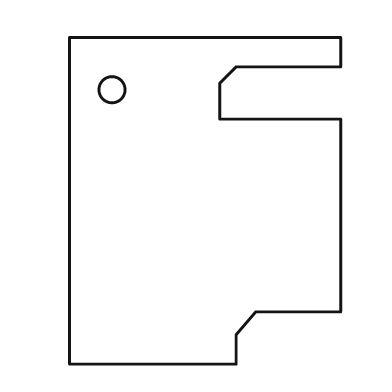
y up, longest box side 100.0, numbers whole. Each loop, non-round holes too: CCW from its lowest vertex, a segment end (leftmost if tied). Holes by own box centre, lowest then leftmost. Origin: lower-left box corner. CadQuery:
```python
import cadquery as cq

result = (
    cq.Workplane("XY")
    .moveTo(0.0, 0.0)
    .lineTo(51.0, 0.0)
    .lineTo(51.0, 9.0)
    .lineTo(57.0, 16.0)
    .lineTo(83.0, 16.0)
    .lineTo(83.0, 75.0)
    .lineTo(46.0, 75.0)
    .lineTo(46.0, 86.0)
    .lineTo(51.0, 91.0)
    .lineTo(83.0, 91.0)
    .lineTo(83.0, 100.0)
    .lineTo(0.0, 100.0)
    .close()
    .moveTo(13.0, 84.0)
    .circle(4.0)
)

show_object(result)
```